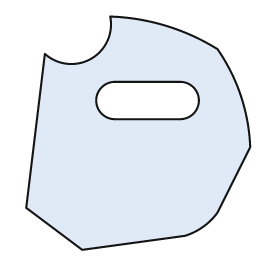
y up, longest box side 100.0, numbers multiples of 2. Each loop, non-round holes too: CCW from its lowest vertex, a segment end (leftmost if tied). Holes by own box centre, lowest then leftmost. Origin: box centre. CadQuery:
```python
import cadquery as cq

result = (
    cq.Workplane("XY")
    .moveTo(-24.0, -50.0)
    .lineTo(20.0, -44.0)
    .threePointArc((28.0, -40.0), (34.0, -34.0))
    .lineTo(48.0, -6.0)
    .threePointArc((44.0, 16.0), (34.0, 36.0))
    .threePointArc((12.0, 46.0), (-12.0, 50.0))
    .threePointArc((-20.0, 32.0), (-40.0, 34.0))
    .lineTo(-48.0, -32.0)
    .close()
    .moveTo(-10.0, 6.0)
    .lineTo(18.0, 6.0)
    .threePointArc((26.0, 14.0), (18.0, 22.0))
    .lineTo(-10.0, 22.0)
    .threePointArc((-18.0, 14.0), (-10.0, 6.0))
    .close()
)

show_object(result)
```